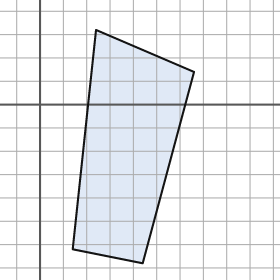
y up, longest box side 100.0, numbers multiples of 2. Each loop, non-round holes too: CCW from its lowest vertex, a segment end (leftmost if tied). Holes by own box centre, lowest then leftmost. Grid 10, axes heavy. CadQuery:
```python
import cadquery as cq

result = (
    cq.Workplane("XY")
    .moveTo(44.0, -68.0)
    .lineTo(66.0, 14.0)
    .lineTo(24.0, 32.0)
    .lineTo(14.0, -62.0)
    .close()
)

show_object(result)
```